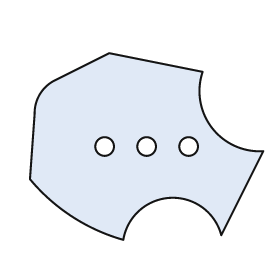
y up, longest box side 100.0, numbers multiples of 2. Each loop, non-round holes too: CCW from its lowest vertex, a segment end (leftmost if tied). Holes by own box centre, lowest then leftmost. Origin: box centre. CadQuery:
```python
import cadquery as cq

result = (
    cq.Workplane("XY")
    .moveTo(-10.0, -40.0)
    .threePointArc((10.0, -22.0), (32.0, -38.0))
    .lineTo(50.0, -2.0)
    .threePointArc((28.0, 8.0), (24.0, 32.0))
    .lineTo(-16.0, 40.0)
    .lineTo(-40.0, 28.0)
    .threePointArc((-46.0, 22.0), (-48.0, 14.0))
    .lineTo(-50.0, -14.0)
    .threePointArc((-32.0, -30.0), (-10.0, -40.0))
    .close()
    .moveTo(-18.0, 0.0)
    .circle(4.0)
    .moveTo(0.0, 0.0)
    .circle(4.0)
    .moveTo(18.0, 0.0)
    .circle(4.0)
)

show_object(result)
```